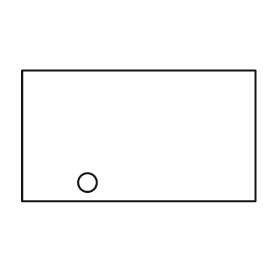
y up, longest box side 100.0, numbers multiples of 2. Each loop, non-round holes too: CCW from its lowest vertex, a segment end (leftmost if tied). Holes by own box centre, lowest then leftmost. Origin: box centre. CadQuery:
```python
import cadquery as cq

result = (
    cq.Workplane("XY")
    .moveTo(-50.0, -28.0)
    .lineTo(50.0, -28.0)
    .lineTo(50.0, 28.0)
    .lineTo(-50.0, 28.0)
    .close()
    .moveTo(-22.0, -20.0)
    .circle(4.0)
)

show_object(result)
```